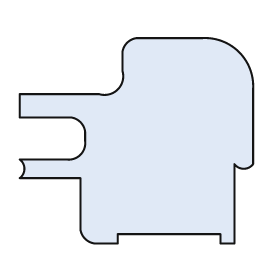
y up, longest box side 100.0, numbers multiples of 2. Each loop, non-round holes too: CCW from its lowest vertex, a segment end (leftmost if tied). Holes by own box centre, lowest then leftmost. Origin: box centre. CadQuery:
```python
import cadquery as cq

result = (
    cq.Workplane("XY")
    .moveTo(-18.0, -44.0)
    .lineTo(-8.0, -44.0)
    .lineTo(-8.0, -40.0)
    .lineTo(36.0, -40.0)
    .lineTo(36.0, -44.0)
    .lineTo(42.0, -44.0)
    .lineTo(42.0, -10.0)
    .threePointArc((46.0, -12.0), (50.0, -10.0))
    .lineTo(50.0, 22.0)
    .threePointArc((44.0, 38.0), (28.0, 44.0))
    .lineTo(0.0, 44.0)
    .threePointArc((-4.0, 42.0), (-6.0, 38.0))
    .lineTo(-6.0, 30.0)
    .threePointArc((-8.0, 22.0), (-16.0, 20.0))
    .lineTo(-50.0, 20.0)
    .lineTo(-50.0, 10.0)
    .lineTo(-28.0, 10.0)
    .threePointArc((-24.0, 8.0), (-22.0, 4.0))
    .lineTo(-22.0, 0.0)
    .threePointArc((-24.0, -6.0), (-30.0, -8.0))
    .lineTo(-50.0, -8.0)
    .threePointArc((-48.0, -12.0), (-50.0, -16.0))
    .lineTo(-24.0, -16.0)
    .lineTo(-24.0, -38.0)
    .threePointArc((-22.0, -42.0), (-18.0, -44.0))
    .close()
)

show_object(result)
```